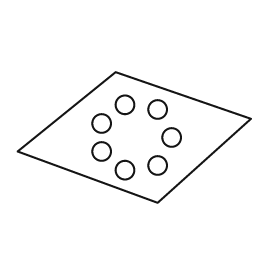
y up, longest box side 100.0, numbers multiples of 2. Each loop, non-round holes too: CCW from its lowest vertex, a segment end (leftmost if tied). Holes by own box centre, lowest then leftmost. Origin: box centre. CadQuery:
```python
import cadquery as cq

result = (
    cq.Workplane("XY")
    .moveTo(10.0, -28.0)
    .lineTo(50.0, 8.0)
    .lineTo(-8.0, 28.0)
    .lineTo(-50.0, -6.0)
    .close()
    .moveTo(-4.0, -14.0)
    .circle(4.0)
    .moveTo(10.0, -12.0)
    .circle(4.0)
    .moveTo(-14.0, -6.0)
    .circle(4.0)
    .moveTo(16.0, 0.0)
    .circle(4.0)
    .moveTo(-14.0, 6.0)
    .circle(4.0)
    .moveTo(10.0, 12.0)
    .circle(4.0)
    .moveTo(-4.0, 14.0)
    .circle(4.0)
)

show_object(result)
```